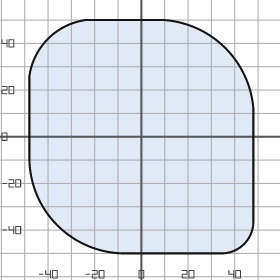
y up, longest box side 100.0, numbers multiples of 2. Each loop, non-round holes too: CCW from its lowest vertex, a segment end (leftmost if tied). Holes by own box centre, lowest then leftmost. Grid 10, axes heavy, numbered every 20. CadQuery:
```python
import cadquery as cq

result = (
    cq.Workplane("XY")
    .moveTo(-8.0, -50.0)
    .lineTo(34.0, -50.0)
    .threePointArc((44.0, -46.0), (48.0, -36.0))
    .lineTo(48.0, 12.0)
    .threePointArc((36.0, 38.0), (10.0, 50.0))
    .lineTo(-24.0, 50.0)
    .threePointArc((-40.0, 42.0), (-48.0, 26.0))
    .lineTo(-48.0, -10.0)
    .threePointArc((-36.0, -38.0), (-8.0, -50.0))
    .close()
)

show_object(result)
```